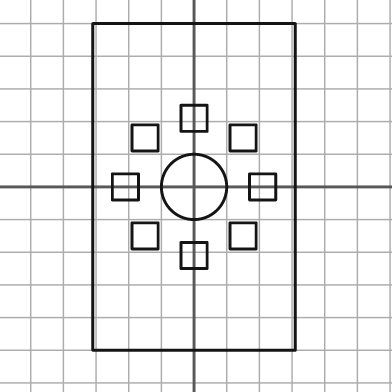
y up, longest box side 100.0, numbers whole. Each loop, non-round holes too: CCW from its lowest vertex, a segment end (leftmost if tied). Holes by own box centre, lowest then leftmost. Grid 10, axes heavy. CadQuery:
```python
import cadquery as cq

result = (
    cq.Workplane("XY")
    .moveTo(-31.0, -50.0)
    .lineTo(31.0, -50.0)
    .lineTo(31.0, 50.0)
    .lineTo(-31.0, 50.0)
    .close()
    .moveTo(-4.0, -25.0)
    .lineTo(4.0, -25.0)
    .lineTo(4.0, -17.0)
    .lineTo(-4.0, -17.0)
    .close()
    .moveTo(-19.0, -19.0)
    .lineTo(-11.0, -19.0)
    .lineTo(-11.0, -11.0)
    .lineTo(-19.0, -11.0)
    .close()
    .moveTo(11.0, -19.0)
    .lineTo(19.0, -19.0)
    .lineTo(19.0, -11.0)
    .lineTo(11.0, -11.0)
    .close()
    .moveTo(-25.0, -4.0)
    .lineTo(-17.0, -4.0)
    .lineTo(-17.0, 4.0)
    .lineTo(-25.0, 4.0)
    .close()
    .moveTo(0.0, 0.0)
    .circle(10.0)
    .moveTo(17.0, -4.0)
    .lineTo(25.0, -4.0)
    .lineTo(25.0, 4.0)
    .lineTo(17.0, 4.0)
    .close()
    .moveTo(-19.0, 11.0)
    .lineTo(-11.0, 11.0)
    .lineTo(-11.0, 19.0)
    .lineTo(-19.0, 19.0)
    .close()
    .moveTo(11.0, 11.0)
    .lineTo(19.0, 11.0)
    .lineTo(19.0, 19.0)
    .lineTo(11.0, 19.0)
    .close()
    .moveTo(-4.0, 17.0)
    .lineTo(4.0, 17.0)
    .lineTo(4.0, 25.0)
    .lineTo(-4.0, 25.0)
    .close()
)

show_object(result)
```